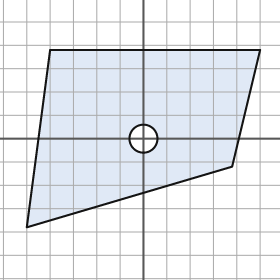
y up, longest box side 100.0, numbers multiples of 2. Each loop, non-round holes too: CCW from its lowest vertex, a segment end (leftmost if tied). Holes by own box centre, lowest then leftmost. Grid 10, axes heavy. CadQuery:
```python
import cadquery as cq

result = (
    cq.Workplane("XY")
    .moveTo(-50.0, -38.0)
    .lineTo(38.0, -12.0)
    .lineTo(50.0, 38.0)
    .lineTo(-40.0, 38.0)
    .close()
    .moveTo(0.0, 0.0)
    .circle(6.0)
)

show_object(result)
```